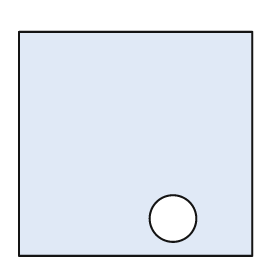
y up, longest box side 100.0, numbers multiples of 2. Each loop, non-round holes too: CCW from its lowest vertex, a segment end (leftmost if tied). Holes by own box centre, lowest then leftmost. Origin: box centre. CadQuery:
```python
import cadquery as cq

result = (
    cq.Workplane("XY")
    .moveTo(-50.0, -48.0)
    .lineTo(50.0, -48.0)
    .lineTo(50.0, 48.0)
    .lineTo(-50.0, 48.0)
    .close()
    .moveTo(16.0, -32.0)
    .circle(10.0)
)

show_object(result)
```